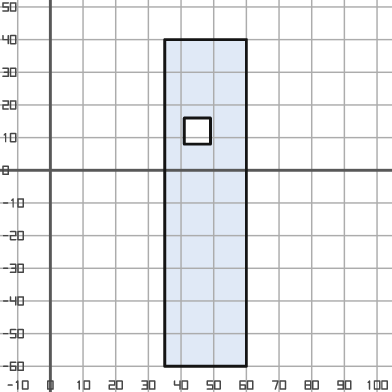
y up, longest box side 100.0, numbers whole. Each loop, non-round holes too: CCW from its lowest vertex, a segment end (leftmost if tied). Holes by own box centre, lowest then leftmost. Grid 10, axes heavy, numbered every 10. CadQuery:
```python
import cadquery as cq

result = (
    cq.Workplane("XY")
    .moveTo(35.0, -60.0)
    .lineTo(60.0, -60.0)
    .lineTo(60.0, 40.0)
    .lineTo(35.0, 40.0)
    .close()
    .moveTo(41.0, 8.0)
    .lineTo(49.0, 8.0)
    .lineTo(49.0, 16.0)
    .lineTo(41.0, 16.0)
    .close()
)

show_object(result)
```